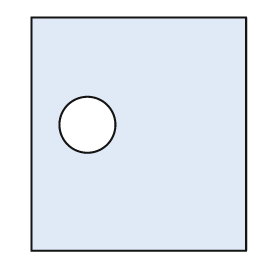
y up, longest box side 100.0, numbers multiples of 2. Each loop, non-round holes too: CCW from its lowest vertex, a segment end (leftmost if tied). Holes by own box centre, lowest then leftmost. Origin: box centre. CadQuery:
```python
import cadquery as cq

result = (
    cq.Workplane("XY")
    .moveTo(-46.0, -50.0)
    .lineTo(46.0, -50.0)
    .lineTo(46.0, 50.0)
    .lineTo(-46.0, 50.0)
    .close()
    .moveTo(-22.0, 4.0)
    .circle(12.0)
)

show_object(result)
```